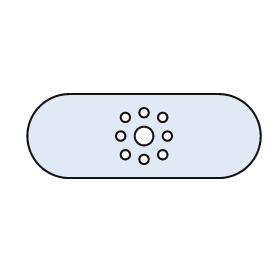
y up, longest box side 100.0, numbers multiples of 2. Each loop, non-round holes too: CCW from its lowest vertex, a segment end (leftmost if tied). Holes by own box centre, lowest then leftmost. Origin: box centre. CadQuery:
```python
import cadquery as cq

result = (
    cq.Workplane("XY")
    .moveTo(-32.0, -18.0)
    .lineTo(32.0, -18.0)
    .threePointArc((50.0, 0.0), (32.0, 18.0))
    .lineTo(-32.0, 18.0)
    .threePointArc((-50.0, 0.0), (-32.0, -18.0))
    .close()
    .moveTo(0.0, -10.0)
    .circle(2.0)
    .moveTo(-8.0, -8.0)
    .circle(2.0)
    .moveTo(8.0, -8.0)
    .circle(2.0)
    .moveTo(-10.0, 0.0)
    .circle(2.0)
    .moveTo(0.0, 0.0)
    .circle(4.0)
    .moveTo(10.0, 0.0)
    .circle(2.0)
    .moveTo(-8.0, 8.0)
    .circle(2.0)
    .moveTo(8.0, 8.0)
    .circle(2.0)
    .moveTo(0.0, 10.0)
    .circle(2.0)
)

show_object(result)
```